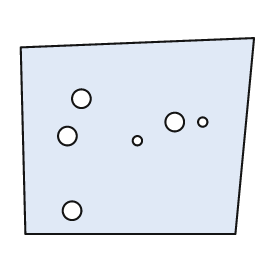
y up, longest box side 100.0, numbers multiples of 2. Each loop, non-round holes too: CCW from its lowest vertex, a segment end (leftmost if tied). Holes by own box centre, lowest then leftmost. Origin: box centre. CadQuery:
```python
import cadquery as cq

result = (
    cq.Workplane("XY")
    .moveTo(-48.0, -42.0)
    .lineTo(42.0, -42.0)
    .lineTo(50.0, 42.0)
    .lineTo(-50.0, 38.0)
    .close()
    .moveTo(-28.0, -32.0)
    .circle(4.0)
    .moveTo(0.0, -2.0)
    .circle(2.0)
    .moveTo(-30.0, 0.0)
    .circle(4.0)
    .moveTo(16.0, 6.0)
    .circle(4.0)
    .moveTo(28.0, 6.0)
    .circle(2.0)
    .moveTo(-24.0, 16.0)
    .circle(4.0)
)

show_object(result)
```